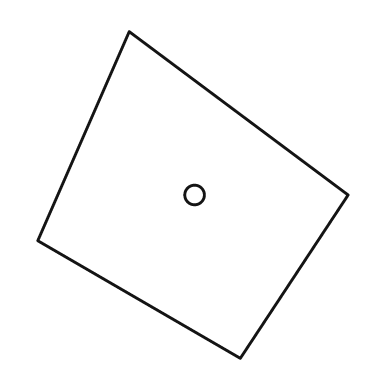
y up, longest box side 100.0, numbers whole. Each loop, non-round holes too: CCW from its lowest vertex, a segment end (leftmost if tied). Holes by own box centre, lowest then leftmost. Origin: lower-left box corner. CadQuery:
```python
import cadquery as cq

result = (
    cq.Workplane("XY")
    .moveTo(62.0, 0.0)
    .lineTo(95.0, 50.0)
    .lineTo(28.0, 100.0)
    .lineTo(0.0, 36.0)
    .close()
    .moveTo(48.0, 50.0)
    .circle(3.0)
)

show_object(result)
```